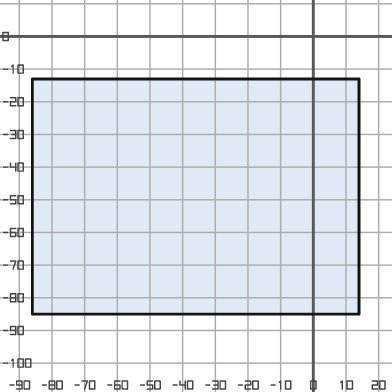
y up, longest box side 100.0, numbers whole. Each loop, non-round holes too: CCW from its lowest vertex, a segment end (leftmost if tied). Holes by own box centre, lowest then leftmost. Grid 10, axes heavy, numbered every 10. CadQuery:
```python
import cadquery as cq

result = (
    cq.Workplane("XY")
    .moveTo(-86.0, -85.0)
    .lineTo(14.0, -85.0)
    .lineTo(14.0, -13.0)
    .lineTo(-86.0, -13.0)
    .close()
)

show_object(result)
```